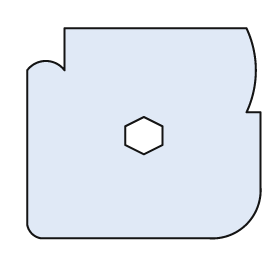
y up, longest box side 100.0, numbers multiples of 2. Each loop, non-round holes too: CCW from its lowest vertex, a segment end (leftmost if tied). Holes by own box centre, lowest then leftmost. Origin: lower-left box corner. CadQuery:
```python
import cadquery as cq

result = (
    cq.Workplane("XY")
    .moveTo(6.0, 0.0)
    .lineTo(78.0, 0.0)
    .threePointArc((94.0, 6.0), (100.0, 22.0))
    .lineTo(100.0, 54.0)
    .lineTo(94.0, 54.0)
    .threePointArc((98.0, 72.0), (94.0, 90.0))
    .lineTo(16.0, 90.0)
    .lineTo(16.0, 72.0)
    .threePointArc((8.0, 76.0), (0.0, 72.0))
    .lineTo(0.0, 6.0)
    .threePointArc((2.0, 2.0), (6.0, 0.0))
    .close()
    .moveTo(50.0, 36.0)
    .lineTo(58.0, 40.0)
    .lineTo(58.0, 48.0)
    .lineTo(50.0, 52.0)
    .lineTo(42.0, 48.0)
    .lineTo(42.0, 40.0)
    .close()
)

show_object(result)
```